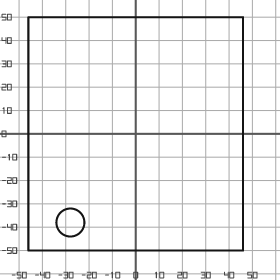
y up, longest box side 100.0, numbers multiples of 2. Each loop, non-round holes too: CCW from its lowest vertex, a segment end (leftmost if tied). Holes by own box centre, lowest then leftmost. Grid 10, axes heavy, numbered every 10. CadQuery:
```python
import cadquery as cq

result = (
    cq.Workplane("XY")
    .moveTo(-46.0, -50.0)
    .lineTo(46.0, -50.0)
    .lineTo(46.0, 50.0)
    .lineTo(-46.0, 50.0)
    .close()
    .moveTo(-28.0, -38.0)
    .circle(6.0)
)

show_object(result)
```